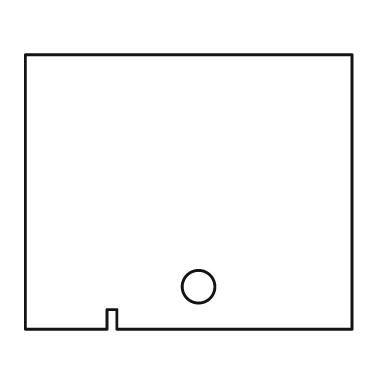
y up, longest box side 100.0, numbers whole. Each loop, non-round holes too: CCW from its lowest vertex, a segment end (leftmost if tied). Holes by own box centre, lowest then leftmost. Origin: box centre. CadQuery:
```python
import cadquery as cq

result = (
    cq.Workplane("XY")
    .moveTo(-50.0, -42.0)
    .lineTo(-25.0, -42.0)
    .lineTo(-25.0, -36.0)
    .lineTo(-22.0, -36.0)
    .lineTo(-22.0, -42.0)
    .lineTo(50.0, -42.0)
    .lineTo(50.0, 42.0)
    .lineTo(-50.0, 42.0)
    .close()
    .moveTo(3.0, -29.0)
    .circle(5.0)
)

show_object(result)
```